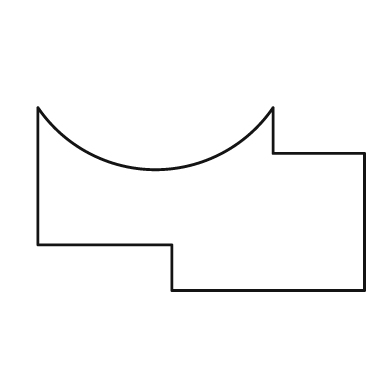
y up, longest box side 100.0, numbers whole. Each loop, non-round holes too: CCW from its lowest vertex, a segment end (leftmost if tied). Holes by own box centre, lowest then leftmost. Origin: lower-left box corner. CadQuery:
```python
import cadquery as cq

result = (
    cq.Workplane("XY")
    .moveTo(41.0, 0.0)
    .lineTo(100.0, 0.0)
    .lineTo(100.0, 42.0)
    .lineTo(72.0, 42.0)
    .lineTo(72.0, 56.0)
    .threePointArc((36.0, 37.0), (0.0, 56.0))
    .lineTo(0.0, 14.0)
    .lineTo(41.0, 14.0)
    .close()
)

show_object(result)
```